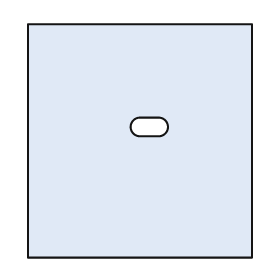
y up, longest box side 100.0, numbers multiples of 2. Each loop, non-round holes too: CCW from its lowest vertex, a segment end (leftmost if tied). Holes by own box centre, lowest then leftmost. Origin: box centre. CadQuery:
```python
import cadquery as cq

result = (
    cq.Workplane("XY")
    .moveTo(-48.0, -50.0)
    .lineTo(48.0, -50.0)
    .lineTo(48.0, 50.0)
    .lineTo(-48.0, 50.0)
    .close()
    .moveTo(0.0, 2.0)
    .lineTo(8.0, 2.0)
    .threePointArc((12.0, 6.0), (8.0, 10.0))
    .lineTo(0.0, 10.0)
    .threePointArc((-4.0, 6.0), (0.0, 2.0))
    .close()
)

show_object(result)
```